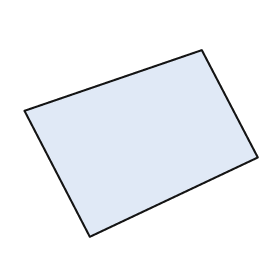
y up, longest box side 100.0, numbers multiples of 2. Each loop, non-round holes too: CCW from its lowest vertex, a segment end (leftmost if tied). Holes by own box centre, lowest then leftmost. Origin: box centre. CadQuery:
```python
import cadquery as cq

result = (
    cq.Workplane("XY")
    .moveTo(-22.0, -40.0)
    .lineTo(50.0, -6.0)
    .lineTo(26.0, 40.0)
    .lineTo(-50.0, 14.0)
    .close()
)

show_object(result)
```